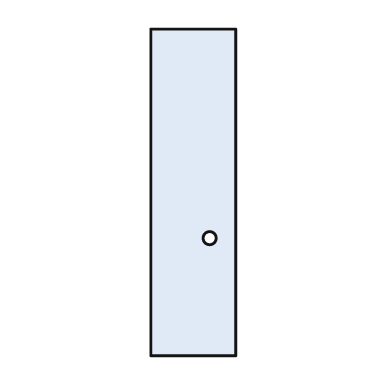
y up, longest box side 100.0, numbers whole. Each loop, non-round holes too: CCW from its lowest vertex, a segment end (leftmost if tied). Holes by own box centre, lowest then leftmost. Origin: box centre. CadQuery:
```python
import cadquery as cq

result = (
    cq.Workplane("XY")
    .moveTo(-13.0, -50.0)
    .lineTo(13.0, -50.0)
    .lineTo(13.0, 50.0)
    .lineTo(-13.0, 50.0)
    .close()
    .moveTo(5.0, -14.0)
    .circle(2.0)
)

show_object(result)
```